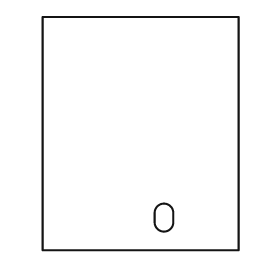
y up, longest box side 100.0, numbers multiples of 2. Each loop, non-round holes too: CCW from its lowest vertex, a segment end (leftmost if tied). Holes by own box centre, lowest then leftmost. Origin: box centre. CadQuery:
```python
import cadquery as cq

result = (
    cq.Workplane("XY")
    .moveTo(-42.0, -50.0)
    .lineTo(42.0, -50.0)
    .lineTo(42.0, 50.0)
    .lineTo(-42.0, 50.0)
    .close()
    .moveTo(6.0, -38.0)
    .threePointArc((10.0, -42.0), (14.0, -38.0))
    .lineTo(14.0, -34.0)
    .threePointArc((10.0, -30.0), (6.0, -34.0))
    .close()
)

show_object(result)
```